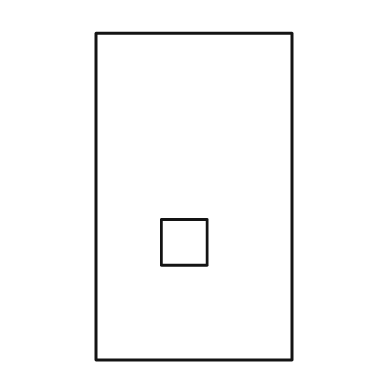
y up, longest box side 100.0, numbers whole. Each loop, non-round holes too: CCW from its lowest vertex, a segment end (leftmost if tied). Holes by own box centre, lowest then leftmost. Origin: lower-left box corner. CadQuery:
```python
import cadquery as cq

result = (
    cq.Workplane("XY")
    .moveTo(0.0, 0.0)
    .lineTo(60.0, 0.0)
    .lineTo(60.0, 100.0)
    .lineTo(0.0, 100.0)
    .close()
    .moveTo(20.0, 29.0)
    .lineTo(34.0, 29.0)
    .lineTo(34.0, 43.0)
    .lineTo(20.0, 43.0)
    .close()
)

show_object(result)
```